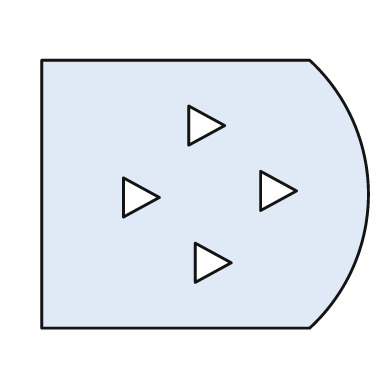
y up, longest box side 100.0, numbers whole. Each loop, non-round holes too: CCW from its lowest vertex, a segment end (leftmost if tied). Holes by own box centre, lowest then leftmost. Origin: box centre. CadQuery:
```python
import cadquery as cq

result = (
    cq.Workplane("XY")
    .moveTo(-50.0, -41.0)
    .lineTo(32.0, -41.0)
    .threePointArc((50.0, 0.0), (32.0, 41.0))
    .lineTo(-50.0, 41.0)
    .close()
    .moveTo(-3.0, -27.0)
    .lineTo(8.0, -21.0)
    .lineTo(-3.0, -15.0)
    .close()
    .moveTo(-25.0, -7.0)
    .lineTo(-14.0, -1.0)
    .lineTo(-25.0, 5.0)
    .close()
    .moveTo(17.0, -5.0)
    .lineTo(28.0, 1.0)
    .lineTo(17.0, 7.0)
    .close()
    .moveTo(-5.0, 15.0)
    .lineTo(6.0, 21.0)
    .lineTo(-5.0, 27.0)
    .close()
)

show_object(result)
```